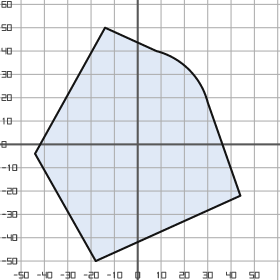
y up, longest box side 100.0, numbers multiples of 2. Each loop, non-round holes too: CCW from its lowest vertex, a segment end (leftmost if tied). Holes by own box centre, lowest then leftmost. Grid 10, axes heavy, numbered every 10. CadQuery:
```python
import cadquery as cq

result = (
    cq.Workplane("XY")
    .moveTo(-18.0, -50.0)
    .lineTo(44.0, -22.0)
    .lineTo(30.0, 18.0)
    .threePointArc((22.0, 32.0), (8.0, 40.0))
    .lineTo(-14.0, 50.0)
    .lineTo(-44.0, -4.0)
    .close()
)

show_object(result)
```